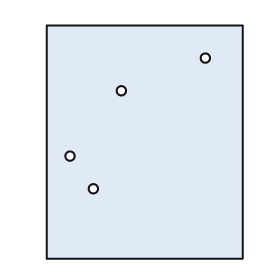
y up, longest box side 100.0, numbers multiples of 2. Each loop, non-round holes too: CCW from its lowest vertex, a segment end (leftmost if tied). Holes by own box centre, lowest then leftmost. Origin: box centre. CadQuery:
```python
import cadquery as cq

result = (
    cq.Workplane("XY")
    .moveTo(-42.0, -50.0)
    .lineTo(42.0, -50.0)
    .lineTo(42.0, 50.0)
    .lineTo(-42.0, 50.0)
    .close()
    .moveTo(-22.0, -20.0)
    .circle(2.0)
    .moveTo(-32.0, -6.0)
    .circle(2.0)
    .moveTo(-10.0, 22.0)
    .circle(2.0)
    .moveTo(26.0, 36.0)
    .circle(2.0)
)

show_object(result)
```